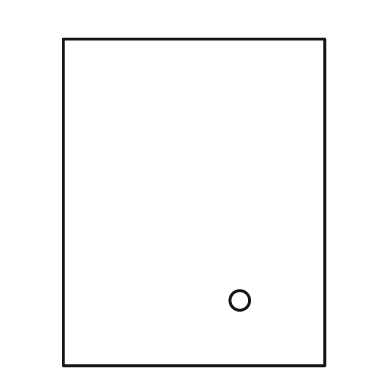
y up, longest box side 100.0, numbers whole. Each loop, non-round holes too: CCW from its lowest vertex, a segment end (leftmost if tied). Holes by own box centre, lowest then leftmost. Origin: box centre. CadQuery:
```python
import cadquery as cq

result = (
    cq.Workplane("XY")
    .moveTo(-40.0, -50.0)
    .lineTo(40.0, -50.0)
    .lineTo(40.0, 50.0)
    .lineTo(-40.0, 50.0)
    .close()
    .moveTo(14.0, -30.0)
    .circle(3.0)
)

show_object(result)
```